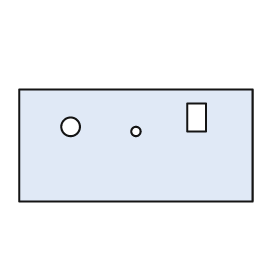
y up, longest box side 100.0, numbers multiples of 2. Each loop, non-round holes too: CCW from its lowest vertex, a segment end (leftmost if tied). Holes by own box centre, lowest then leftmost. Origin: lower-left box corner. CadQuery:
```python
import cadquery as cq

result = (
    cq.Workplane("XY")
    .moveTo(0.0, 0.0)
    .lineTo(100.0, 0.0)
    .lineTo(100.0, 48.0)
    .lineTo(0.0, 48.0)
    .close()
    .moveTo(50.0, 30.0)
    .circle(2.0)
    .moveTo(22.0, 32.0)
    .circle(4.0)
    .moveTo(72.0, 30.0)
    .lineTo(80.0, 30.0)
    .lineTo(80.0, 42.0)
    .lineTo(72.0, 42.0)
    .close()
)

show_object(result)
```